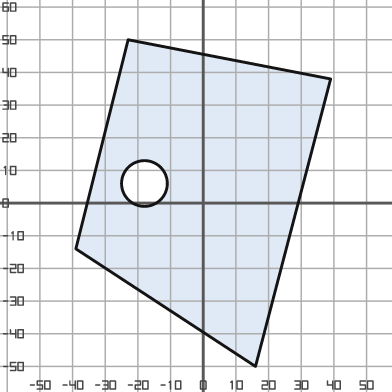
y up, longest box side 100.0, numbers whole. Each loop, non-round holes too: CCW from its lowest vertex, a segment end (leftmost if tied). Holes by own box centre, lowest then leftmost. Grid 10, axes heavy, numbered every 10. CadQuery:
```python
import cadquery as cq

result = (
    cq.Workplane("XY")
    .moveTo(16.0, -50.0)
    .lineTo(39.0, 38.0)
    .lineTo(-23.0, 50.0)
    .lineTo(-39.0, -14.0)
    .close()
    .moveTo(-18.0, 6.0)
    .circle(7.0)
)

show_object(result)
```